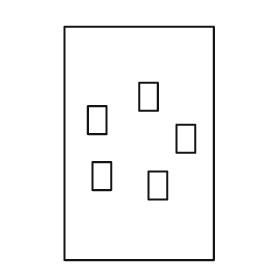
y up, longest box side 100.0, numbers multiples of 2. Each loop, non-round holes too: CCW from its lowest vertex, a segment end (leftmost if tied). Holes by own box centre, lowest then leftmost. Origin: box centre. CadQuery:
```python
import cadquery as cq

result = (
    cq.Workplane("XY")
    .moveTo(-32.0, -50.0)
    .lineTo(32.0, -50.0)
    .lineTo(32.0, 50.0)
    .lineTo(-32.0, 50.0)
    .close()
    .moveTo(4.0, -24.0)
    .lineTo(12.0, -24.0)
    .lineTo(12.0, -12.0)
    .lineTo(4.0, -12.0)
    .close()
    .moveTo(-20.0, -20.0)
    .lineTo(-12.0, -20.0)
    .lineTo(-12.0, -8.0)
    .lineTo(-20.0, -8.0)
    .close()
    .moveTo(16.0, -4.0)
    .lineTo(24.0, -4.0)
    .lineTo(24.0, 8.0)
    .lineTo(16.0, 8.0)
    .close()
    .moveTo(-22.0, 4.0)
    .lineTo(-14.0, 4.0)
    .lineTo(-14.0, 16.0)
    .lineTo(-22.0, 16.0)
    .close()
    .moveTo(0.0, 14.0)
    .lineTo(8.0, 14.0)
    .lineTo(8.0, 26.0)
    .lineTo(0.0, 26.0)
    .close()
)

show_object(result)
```